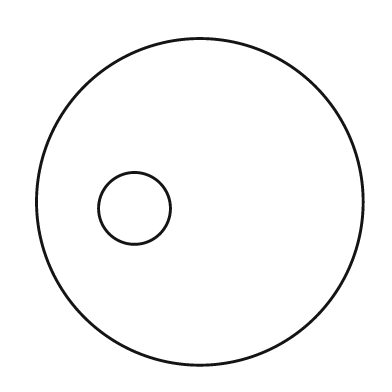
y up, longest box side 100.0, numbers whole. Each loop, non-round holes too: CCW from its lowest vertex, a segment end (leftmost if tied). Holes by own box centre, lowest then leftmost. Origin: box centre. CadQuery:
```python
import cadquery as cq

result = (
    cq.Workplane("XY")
    .moveTo(0.0, 0.0)
    .circle(50.0)
    .moveTo(-20.0, -2.0)
    .circle(11.0)
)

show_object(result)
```